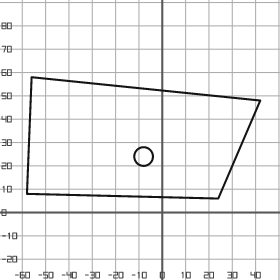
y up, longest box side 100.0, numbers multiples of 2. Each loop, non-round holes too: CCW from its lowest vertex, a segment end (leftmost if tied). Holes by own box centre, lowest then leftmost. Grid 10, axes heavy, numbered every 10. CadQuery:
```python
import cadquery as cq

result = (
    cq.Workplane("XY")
    .moveTo(24.0, 6.0)
    .lineTo(42.0, 48.0)
    .lineTo(-56.0, 58.0)
    .lineTo(-58.0, 8.0)
    .close()
    .moveTo(-8.0, 24.0)
    .circle(4.0)
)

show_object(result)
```